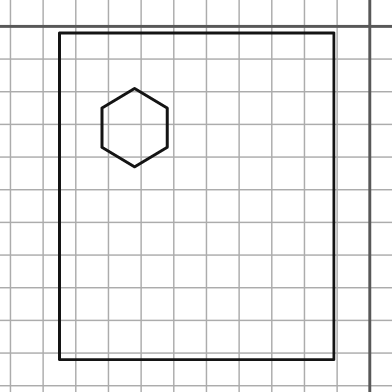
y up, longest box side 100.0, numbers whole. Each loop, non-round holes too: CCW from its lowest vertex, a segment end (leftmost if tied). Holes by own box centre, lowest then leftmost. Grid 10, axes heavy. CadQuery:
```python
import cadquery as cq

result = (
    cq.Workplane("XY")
    .moveTo(-95.0, -102.0)
    .lineTo(-11.0, -102.0)
    .lineTo(-11.0, -2.0)
    .lineTo(-95.0, -2.0)
    .close()
    .moveTo(-72.0, -43.0)
    .lineTo(-62.0, -37.0)
    .lineTo(-62.0, -25.0)
    .lineTo(-72.0, -19.0)
    .lineTo(-82.0, -25.0)
    .lineTo(-82.0, -37.0)
    .close()
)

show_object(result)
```